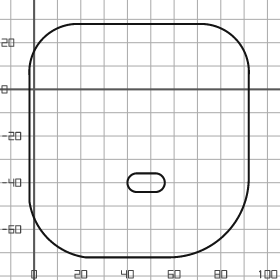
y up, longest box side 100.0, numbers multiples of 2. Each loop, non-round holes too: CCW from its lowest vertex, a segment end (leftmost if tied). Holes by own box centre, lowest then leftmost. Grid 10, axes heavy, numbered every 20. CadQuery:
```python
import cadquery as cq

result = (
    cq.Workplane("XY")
    .moveTo(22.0, -72.0)
    .lineTo(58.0, -72.0)
    .threePointArc((82.0, -62.0), (92.0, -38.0))
    .lineTo(92.0, 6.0)
    .threePointArc((86.0, 22.0), (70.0, 28.0))
    .lineTo(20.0, 28.0)
    .threePointArc((4.0, 22.0), (-2.0, 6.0))
    .lineTo(-2.0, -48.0)
    .threePointArc((6.0, -64.0), (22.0, -72.0))
    .close()
    .moveTo(44.0, -44.0)
    .lineTo(52.0, -44.0)
    .threePointArc((56.0, -40.0), (52.0, -36.0))
    .lineTo(44.0, -36.0)
    .threePointArc((40.0, -40.0), (44.0, -44.0))
    .close()
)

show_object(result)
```